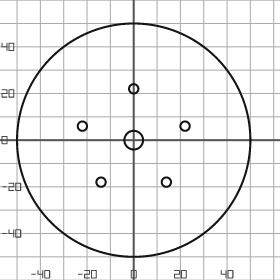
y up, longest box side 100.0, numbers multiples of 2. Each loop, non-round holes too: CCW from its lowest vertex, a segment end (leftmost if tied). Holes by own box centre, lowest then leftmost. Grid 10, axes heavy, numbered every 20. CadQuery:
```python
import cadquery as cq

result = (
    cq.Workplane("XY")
    .moveTo(0.0, 0.0)
    .circle(50.0)
    .moveTo(-14.0, -18.0)
    .circle(2.0)
    .moveTo(14.0, -18.0)
    .circle(2.0)
    .moveTo(0.0, 0.0)
    .circle(4.0)
    .moveTo(-22.0, 6.0)
    .circle(2.0)
    .moveTo(22.0, 6.0)
    .circle(2.0)
    .moveTo(0.0, 22.0)
    .circle(2.0)
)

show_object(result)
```